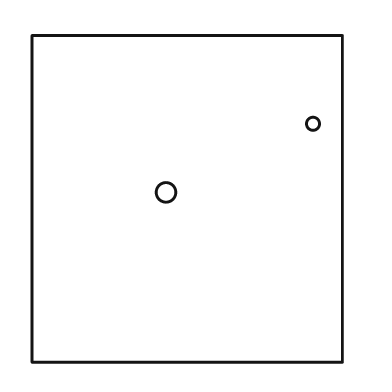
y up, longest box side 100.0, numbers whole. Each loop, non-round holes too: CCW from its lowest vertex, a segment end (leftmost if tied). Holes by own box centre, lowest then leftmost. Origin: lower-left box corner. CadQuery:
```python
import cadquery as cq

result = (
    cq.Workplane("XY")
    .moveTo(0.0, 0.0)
    .lineTo(95.0, 0.0)
    .lineTo(95.0, 100.0)
    .lineTo(0.0, 100.0)
    .close()
    .moveTo(41.0, 52.0)
    .circle(3.0)
    .moveTo(86.0, 73.0)
    .circle(2.0)
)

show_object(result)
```